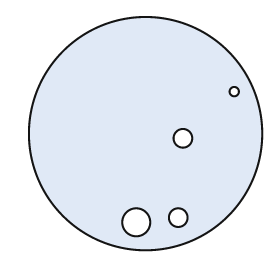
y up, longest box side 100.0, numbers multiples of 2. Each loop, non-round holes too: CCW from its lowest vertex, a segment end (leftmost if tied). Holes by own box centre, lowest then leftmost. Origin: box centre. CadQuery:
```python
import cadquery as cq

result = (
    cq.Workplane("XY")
    .moveTo(0.0, 0.0)
    .circle(50.0)
    .moveTo(-4.0, -38.0)
    .circle(6.0)
    .moveTo(14.0, -36.0)
    .circle(4.0)
    .moveTo(16.0, -2.0)
    .circle(4.0)
    .moveTo(38.0, 18.0)
    .circle(2.0)
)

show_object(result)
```